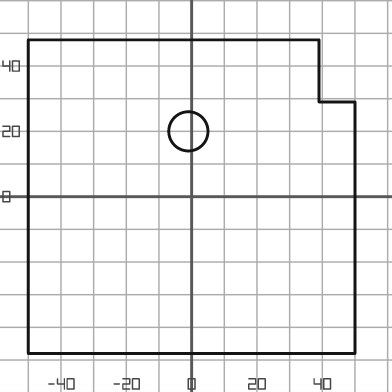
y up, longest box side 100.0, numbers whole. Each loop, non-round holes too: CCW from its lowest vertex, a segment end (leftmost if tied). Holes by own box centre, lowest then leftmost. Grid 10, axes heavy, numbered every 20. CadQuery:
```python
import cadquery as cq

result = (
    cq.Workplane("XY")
    .moveTo(-50.0, -48.0)
    .lineTo(50.0, -48.0)
    .lineTo(50.0, 29.0)
    .lineTo(39.0, 29.0)
    .lineTo(39.0, 48.0)
    .lineTo(-50.0, 48.0)
    .close()
    .moveTo(-1.0, 20.0)
    .circle(6.0)
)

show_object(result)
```